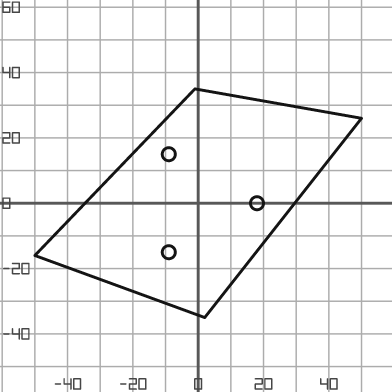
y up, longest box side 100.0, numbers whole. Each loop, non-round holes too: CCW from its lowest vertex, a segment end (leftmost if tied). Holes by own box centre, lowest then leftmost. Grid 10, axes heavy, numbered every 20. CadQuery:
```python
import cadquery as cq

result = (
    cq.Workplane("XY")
    .moveTo(2.0, -35.0)
    .lineTo(50.0, 26.0)
    .lineTo(-1.0, 35.0)
    .lineTo(-50.0, -16.0)
    .close()
    .moveTo(-9.0, -15.0)
    .circle(2.0)
    .moveTo(18.0, 0.0)
    .circle(2.0)
    .moveTo(-9.0, 15.0)
    .circle(2.0)
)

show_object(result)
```